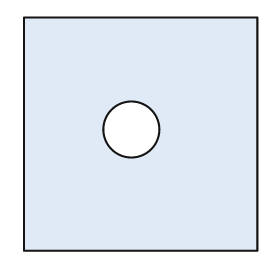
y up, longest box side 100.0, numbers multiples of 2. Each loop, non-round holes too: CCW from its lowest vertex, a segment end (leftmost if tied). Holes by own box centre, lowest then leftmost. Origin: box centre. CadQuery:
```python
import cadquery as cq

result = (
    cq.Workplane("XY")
    .moveTo(-50.0, -50.0)
    .lineTo(50.0, -50.0)
    .lineTo(50.0, 50.0)
    .lineTo(-50.0, 50.0)
    .close()
    .moveTo(-4.0, 2.0)
    .circle(12.0)
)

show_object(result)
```